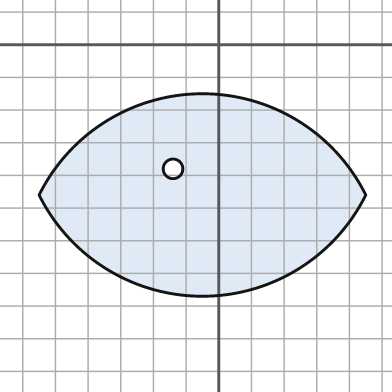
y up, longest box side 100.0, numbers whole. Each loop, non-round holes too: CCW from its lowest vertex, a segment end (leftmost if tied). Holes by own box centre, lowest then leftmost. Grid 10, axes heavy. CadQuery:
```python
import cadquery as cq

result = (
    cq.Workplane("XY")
    .moveTo(-55.0, -46.0)
    .threePointArc((-5.0, -77.0), (45.0, -46.0))
    .threePointArc((-5.0, -15.0), (-55.0, -46.0))
    .close()
    .moveTo(-14.0, -38.0)
    .circle(3.0)
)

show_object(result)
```